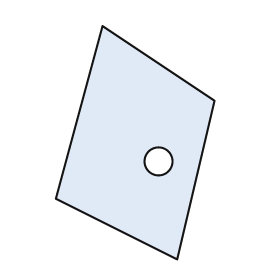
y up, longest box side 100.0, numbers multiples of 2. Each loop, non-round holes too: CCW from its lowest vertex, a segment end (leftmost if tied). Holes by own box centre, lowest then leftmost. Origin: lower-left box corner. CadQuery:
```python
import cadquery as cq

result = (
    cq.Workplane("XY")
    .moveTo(52.0, 0.0)
    .lineTo(68.0, 68.0)
    .lineTo(20.0, 100.0)
    .lineTo(0.0, 26.0)
    .close()
    .moveTo(44.0, 42.0)
    .circle(6.0)
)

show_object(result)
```